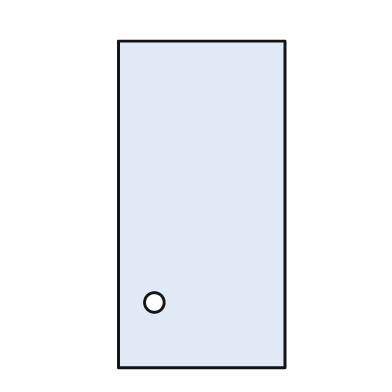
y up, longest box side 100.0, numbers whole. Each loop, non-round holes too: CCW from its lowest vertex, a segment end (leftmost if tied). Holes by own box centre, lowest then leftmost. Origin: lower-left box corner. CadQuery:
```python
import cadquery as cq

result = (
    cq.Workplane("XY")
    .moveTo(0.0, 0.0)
    .lineTo(51.0, 0.0)
    .lineTo(51.0, 100.0)
    .lineTo(0.0, 100.0)
    .close()
    .moveTo(11.0, 20.0)
    .circle(3.0)
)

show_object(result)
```